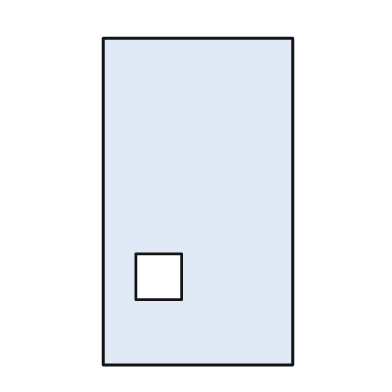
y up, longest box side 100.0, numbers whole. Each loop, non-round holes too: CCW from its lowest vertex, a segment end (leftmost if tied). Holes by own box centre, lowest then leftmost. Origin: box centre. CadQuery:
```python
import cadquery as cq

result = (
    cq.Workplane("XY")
    .moveTo(-29.0, -50.0)
    .lineTo(29.0, -50.0)
    .lineTo(29.0, 50.0)
    .lineTo(-29.0, 50.0)
    .close()
    .moveTo(-19.0, -30.0)
    .lineTo(-5.0, -30.0)
    .lineTo(-5.0, -16.0)
    .lineTo(-19.0, -16.0)
    .close()
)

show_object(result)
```